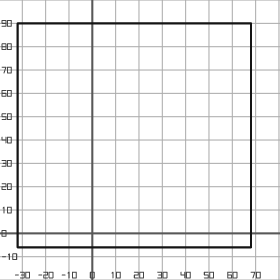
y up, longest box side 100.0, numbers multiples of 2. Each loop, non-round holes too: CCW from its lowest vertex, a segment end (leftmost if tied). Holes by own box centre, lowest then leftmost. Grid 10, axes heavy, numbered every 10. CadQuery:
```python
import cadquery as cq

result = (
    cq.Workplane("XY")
    .moveTo(-32.0, -6.0)
    .lineTo(68.0, -6.0)
    .lineTo(68.0, 90.0)
    .lineTo(-32.0, 90.0)
    .close()
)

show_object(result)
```